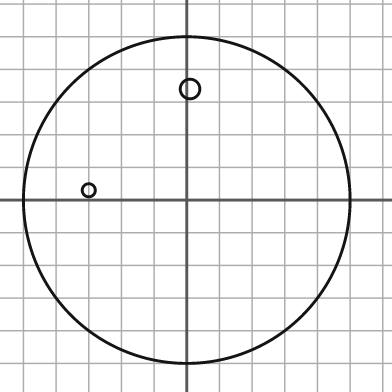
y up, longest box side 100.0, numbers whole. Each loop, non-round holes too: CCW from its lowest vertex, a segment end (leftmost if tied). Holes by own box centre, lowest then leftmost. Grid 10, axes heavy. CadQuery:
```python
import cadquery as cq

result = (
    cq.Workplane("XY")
    .moveTo(0.0, 0.0)
    .circle(50.0)
    .moveTo(-30.0, 3.0)
    .circle(2.0)
    .moveTo(1.0, 34.0)
    .circle(3.0)
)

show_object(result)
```